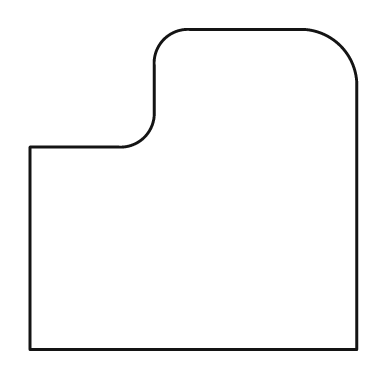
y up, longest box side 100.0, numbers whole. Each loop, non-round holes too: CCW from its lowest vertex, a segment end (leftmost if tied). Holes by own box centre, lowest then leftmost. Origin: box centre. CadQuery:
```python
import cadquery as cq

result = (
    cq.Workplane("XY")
    .moveTo(-50.0, -49.0)
    .lineTo(50.0, -49.0)
    .lineTo(50.0, 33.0)
    .threePointArc((45.0, 44.0), (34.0, 49.0))
    .lineTo(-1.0, 49.0)
    .threePointArc((-9.0, 46.0), (-12.0, 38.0))
    .lineTo(-12.0, 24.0)
    .threePointArc((-15.0, 16.0), (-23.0, 13.0))
    .lineTo(-50.0, 13.0)
    .close()
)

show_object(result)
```